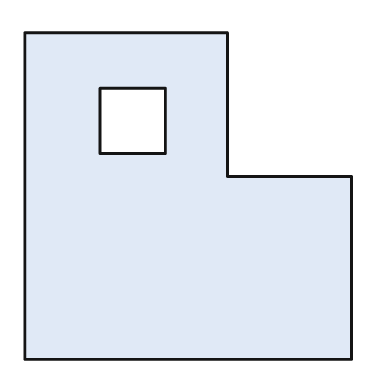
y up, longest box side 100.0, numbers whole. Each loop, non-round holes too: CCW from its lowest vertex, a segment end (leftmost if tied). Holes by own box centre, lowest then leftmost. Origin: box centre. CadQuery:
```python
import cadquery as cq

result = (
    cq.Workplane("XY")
    .moveTo(-50.0, -50.0)
    .lineTo(50.0, -50.0)
    .lineTo(50.0, 6.0)
    .lineTo(12.0, 6.0)
    .lineTo(12.0, 50.0)
    .lineTo(-50.0, 50.0)
    .close()
    .moveTo(-27.0, 13.0)
    .lineTo(-7.0, 13.0)
    .lineTo(-7.0, 33.0)
    .lineTo(-27.0, 33.0)
    .close()
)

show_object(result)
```